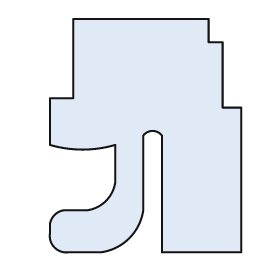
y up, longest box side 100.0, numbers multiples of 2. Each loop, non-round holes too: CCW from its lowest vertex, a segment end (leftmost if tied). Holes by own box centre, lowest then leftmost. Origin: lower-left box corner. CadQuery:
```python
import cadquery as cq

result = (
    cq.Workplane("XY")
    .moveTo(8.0, 0.0)
    .lineTo(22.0, 0.0)
    .threePointArc((34.0, 6.0), (40.0, 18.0))
    .lineTo(40.0, 50.0)
    .threePointArc((44.0, 52.0), (48.0, 50.0))
    .lineTo(48.0, 0.0)
    .lineTo(82.0, 0.0)
    .lineTo(82.0, 62.0)
    .lineTo(74.0, 62.0)
    .lineTo(74.0, 90.0)
    .lineTo(68.0, 90.0)
    .lineTo(68.0, 100.0)
    .lineTo(10.0, 100.0)
    .lineTo(10.0, 66.0)
    .lineTo(0.0, 66.0)
    .lineTo(0.0, 46.0)
    .threePointArc((14.0, 44.0), (28.0, 46.0))
    .lineTo(28.0, 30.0)
    .threePointArc((24.0, 22.0), (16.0, 18.0))
    .lineTo(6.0, 18.0)
    .threePointArc((2.0, 16.0), (0.0, 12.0))
    .lineTo(0.0, 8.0)
    .threePointArc((2.0, 2.0), (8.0, 0.0))
    .close()
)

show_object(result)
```